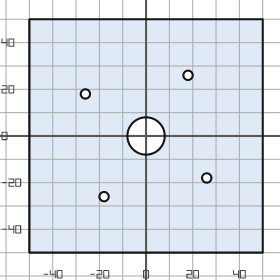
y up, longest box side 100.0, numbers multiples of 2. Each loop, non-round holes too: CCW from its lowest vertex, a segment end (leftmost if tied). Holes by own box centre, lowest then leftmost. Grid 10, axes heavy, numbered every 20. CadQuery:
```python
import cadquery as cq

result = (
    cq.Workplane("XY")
    .moveTo(-50.0, -50.0)
    .lineTo(50.0, -50.0)
    .lineTo(50.0, 50.0)
    .lineTo(-50.0, 50.0)
    .close()
    .moveTo(-18.0, -26.0)
    .circle(2.0)
    .moveTo(26.0, -18.0)
    .circle(2.0)
    .moveTo(0.0, 0.0)
    .circle(8.0)
    .moveTo(-26.0, 18.0)
    .circle(2.0)
    .moveTo(18.0, 26.0)
    .circle(2.0)
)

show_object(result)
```